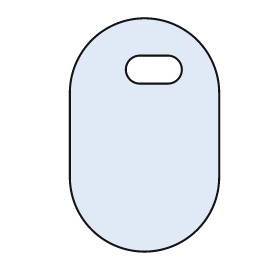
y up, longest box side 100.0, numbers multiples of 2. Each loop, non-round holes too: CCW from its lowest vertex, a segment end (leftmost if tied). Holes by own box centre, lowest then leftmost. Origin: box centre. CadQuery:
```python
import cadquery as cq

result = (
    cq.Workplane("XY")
    .moveTo(-32.0, -18.0)
    .threePointArc((0.0, -50.0), (32.0, -18.0))
    .lineTo(32.0, 18.0)
    .threePointArc((0.0, 50.0), (-32.0, 18.0))
    .close()
    .moveTo(-2.0, 22.0)
    .lineTo(10.0, 22.0)
    .threePointArc((16.0, 28.0), (10.0, 34.0))
    .lineTo(-2.0, 34.0)
    .threePointArc((-8.0, 28.0), (-2.0, 22.0))
    .close()
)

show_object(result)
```